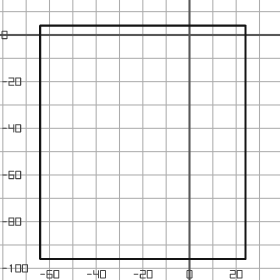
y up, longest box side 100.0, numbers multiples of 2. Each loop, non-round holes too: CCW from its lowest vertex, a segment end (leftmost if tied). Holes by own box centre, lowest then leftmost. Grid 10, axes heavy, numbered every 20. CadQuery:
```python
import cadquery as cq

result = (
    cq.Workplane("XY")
    .moveTo(-64.0, -96.0)
    .lineTo(24.0, -96.0)
    .lineTo(24.0, 4.0)
    .lineTo(-64.0, 4.0)
    .close()
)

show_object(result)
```